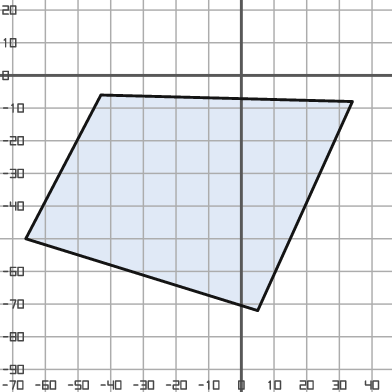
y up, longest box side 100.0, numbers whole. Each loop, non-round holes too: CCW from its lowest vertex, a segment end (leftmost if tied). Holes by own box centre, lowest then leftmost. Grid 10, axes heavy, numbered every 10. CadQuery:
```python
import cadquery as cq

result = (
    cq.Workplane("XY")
    .moveTo(5.0, -72.0)
    .lineTo(34.0, -8.0)
    .lineTo(-43.0, -6.0)
    .lineTo(-66.0, -50.0)
    .close()
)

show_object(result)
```